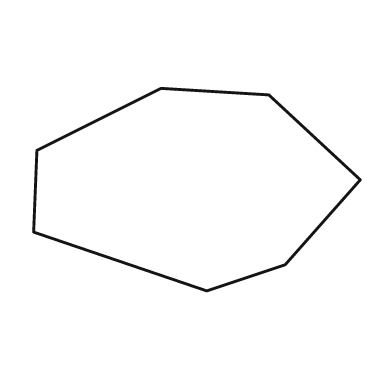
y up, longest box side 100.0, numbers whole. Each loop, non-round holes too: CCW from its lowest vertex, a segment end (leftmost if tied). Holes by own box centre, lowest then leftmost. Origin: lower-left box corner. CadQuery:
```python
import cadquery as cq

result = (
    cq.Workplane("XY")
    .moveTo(53.0, 0.0)
    .lineTo(77.0, 8.0)
    .lineTo(100.0, 34.0)
    .lineTo(72.0, 60.0)
    .lineTo(39.0, 62.0)
    .lineTo(1.0, 43.0)
    .lineTo(0.0, 18.0)
    .close()
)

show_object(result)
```